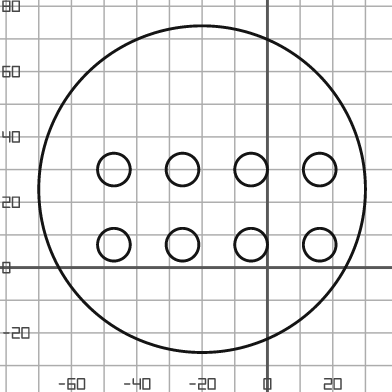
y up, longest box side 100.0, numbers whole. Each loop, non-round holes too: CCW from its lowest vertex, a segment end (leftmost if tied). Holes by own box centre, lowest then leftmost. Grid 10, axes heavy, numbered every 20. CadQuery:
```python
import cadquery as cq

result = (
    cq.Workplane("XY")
    .moveTo(-20.0, 24.0)
    .circle(50.0)
    .moveTo(-47.0, 7.0)
    .circle(5.0)
    .moveTo(-26.0, 7.0)
    .circle(5.0)
    .moveTo(-5.0, 7.0)
    .circle(5.0)
    .moveTo(16.0, 7.0)
    .circle(5.0)
    .moveTo(-47.0, 30.0)
    .circle(5.0)
    .moveTo(-26.0, 30.0)
    .circle(5.0)
    .moveTo(-5.0, 30.0)
    .circle(5.0)
    .moveTo(16.0, 30.0)
    .circle(5.0)
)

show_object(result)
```